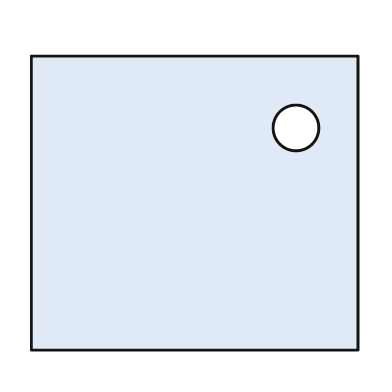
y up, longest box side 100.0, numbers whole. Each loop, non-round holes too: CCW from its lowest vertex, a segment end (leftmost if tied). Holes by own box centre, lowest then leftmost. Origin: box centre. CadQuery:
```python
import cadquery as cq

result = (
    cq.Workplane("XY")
    .moveTo(-50.0, -45.0)
    .lineTo(50.0, -45.0)
    .lineTo(50.0, 45.0)
    .lineTo(-50.0, 45.0)
    .close()
    .moveTo(31.0, 23.0)
    .circle(7.0)
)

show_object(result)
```